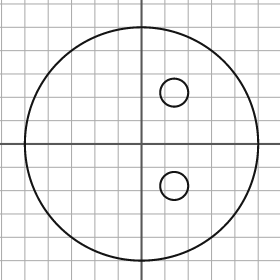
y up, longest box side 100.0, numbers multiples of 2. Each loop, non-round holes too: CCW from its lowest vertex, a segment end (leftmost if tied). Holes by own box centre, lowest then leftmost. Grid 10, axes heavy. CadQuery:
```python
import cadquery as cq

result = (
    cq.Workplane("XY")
    .moveTo(0.0, 0.0)
    .circle(50.0)
    .moveTo(14.0, -18.0)
    .circle(6.0)
    .moveTo(14.0, 22.0)
    .circle(6.0)
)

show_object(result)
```